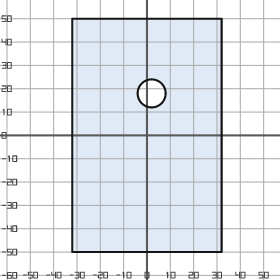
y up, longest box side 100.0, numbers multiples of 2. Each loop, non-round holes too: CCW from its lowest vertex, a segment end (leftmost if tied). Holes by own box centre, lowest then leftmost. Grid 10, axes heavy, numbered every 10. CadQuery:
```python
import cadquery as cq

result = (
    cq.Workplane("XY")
    .moveTo(-32.0, -50.0)
    .lineTo(32.0, -50.0)
    .lineTo(32.0, 50.0)
    .lineTo(-32.0, 50.0)
    .close()
    .moveTo(2.0, 18.0)
    .circle(6.0)
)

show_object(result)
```